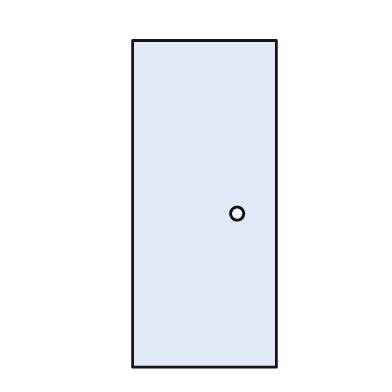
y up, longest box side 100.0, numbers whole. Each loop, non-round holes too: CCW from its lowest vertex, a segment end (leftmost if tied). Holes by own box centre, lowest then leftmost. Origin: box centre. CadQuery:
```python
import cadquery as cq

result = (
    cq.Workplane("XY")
    .moveTo(-22.0, -50.0)
    .lineTo(22.0, -50.0)
    .lineTo(22.0, 50.0)
    .lineTo(-22.0, 50.0)
    .close()
    .moveTo(10.0, -3.0)
    .circle(2.0)
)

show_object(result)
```